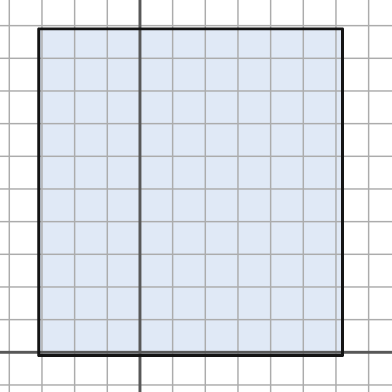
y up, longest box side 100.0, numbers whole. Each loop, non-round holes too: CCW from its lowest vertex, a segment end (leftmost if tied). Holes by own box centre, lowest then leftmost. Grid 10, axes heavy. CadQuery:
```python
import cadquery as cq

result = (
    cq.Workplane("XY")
    .moveTo(-31.0, -1.0)
    .lineTo(62.0, -1.0)
    .lineTo(62.0, 99.0)
    .lineTo(-31.0, 99.0)
    .close()
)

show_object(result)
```